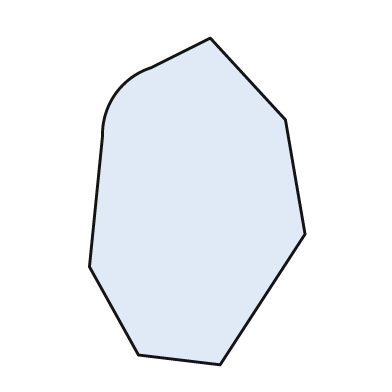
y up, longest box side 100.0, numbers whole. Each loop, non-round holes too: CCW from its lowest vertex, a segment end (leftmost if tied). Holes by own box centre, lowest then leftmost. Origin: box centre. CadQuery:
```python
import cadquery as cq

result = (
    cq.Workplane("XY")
    .moveTo(7.0, -50.0)
    .lineTo(33.0, -10.0)
    .lineTo(27.0, 25.0)
    .lineTo(4.0, 50.0)
    .lineTo(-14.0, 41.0)
    .threePointArc((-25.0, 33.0), (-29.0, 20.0))
    .lineTo(-33.0, -20.0)
    .lineTo(-18.0, -47.0)
    .close()
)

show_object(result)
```